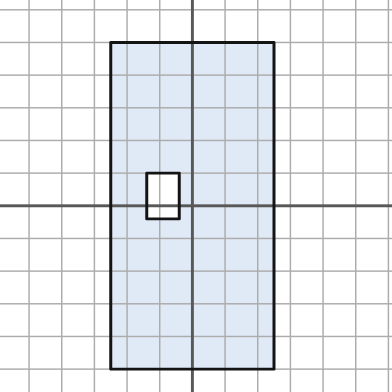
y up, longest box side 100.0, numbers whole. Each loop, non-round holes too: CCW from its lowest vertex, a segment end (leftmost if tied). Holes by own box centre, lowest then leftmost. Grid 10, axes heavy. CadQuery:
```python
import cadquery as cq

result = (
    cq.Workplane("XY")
    .moveTo(-25.0, -50.0)
    .lineTo(25.0, -50.0)
    .lineTo(25.0, 50.0)
    .lineTo(-25.0, 50.0)
    .close()
    .moveTo(-14.0, -4.0)
    .lineTo(-4.0, -4.0)
    .lineTo(-4.0, 10.0)
    .lineTo(-14.0, 10.0)
    .close()
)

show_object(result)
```